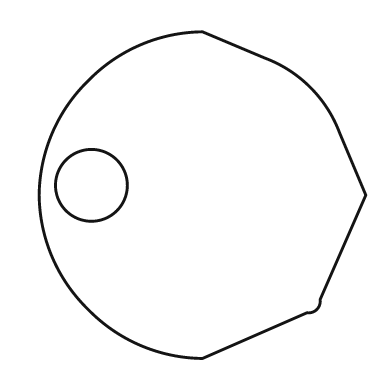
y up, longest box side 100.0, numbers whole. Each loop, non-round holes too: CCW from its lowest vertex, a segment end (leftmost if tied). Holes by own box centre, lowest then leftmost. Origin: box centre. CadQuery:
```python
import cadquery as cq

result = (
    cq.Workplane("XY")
    .moveTo(0.0, -50.0)
    .lineTo(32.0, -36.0)
    .threePointArc((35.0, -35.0), (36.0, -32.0))
    .lineTo(50.0, 0.0)
    .lineTo(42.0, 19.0)
    .threePointArc((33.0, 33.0), (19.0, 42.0))
    .lineTo(0.0, 50.0)
    .threePointArc((-19.0, 46.0), (-35.0, 35.0))
    .threePointArc((-46.0, 19.0), (-50.0, 0.0))
    .threePointArc((-46.0, -19.0), (-35.0, -35.0))
    .threePointArc((-19.0, -46.0), (0.0, -50.0))
    .close()
    .moveTo(-34.0, 3.0)
    .circle(11.0)
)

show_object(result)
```